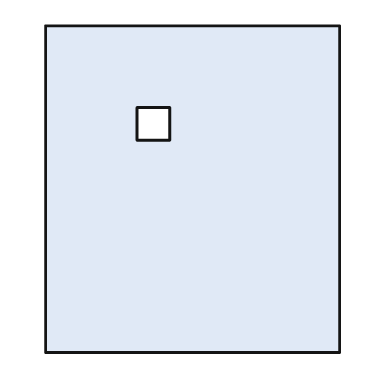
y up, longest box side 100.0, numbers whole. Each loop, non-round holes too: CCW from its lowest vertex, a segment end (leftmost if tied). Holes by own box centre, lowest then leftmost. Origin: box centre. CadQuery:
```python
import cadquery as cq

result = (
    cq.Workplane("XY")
    .moveTo(-45.0, -50.0)
    .lineTo(45.0, -50.0)
    .lineTo(45.0, 50.0)
    .lineTo(-45.0, 50.0)
    .close()
    .moveTo(-17.0, 15.0)
    .lineTo(-7.0, 15.0)
    .lineTo(-7.0, 25.0)
    .lineTo(-17.0, 25.0)
    .close()
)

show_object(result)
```